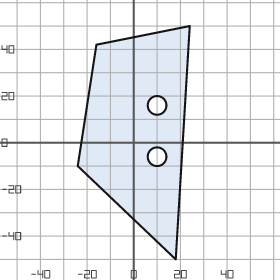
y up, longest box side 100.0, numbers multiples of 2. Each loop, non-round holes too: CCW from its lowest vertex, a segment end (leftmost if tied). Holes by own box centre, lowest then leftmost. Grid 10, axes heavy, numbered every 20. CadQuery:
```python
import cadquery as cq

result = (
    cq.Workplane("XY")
    .moveTo(18.0, -50.0)
    .lineTo(24.0, 50.0)
    .lineTo(-16.0, 42.0)
    .lineTo(-24.0, -10.0)
    .close()
    .moveTo(10.0, -6.0)
    .circle(4.0)
    .moveTo(10.0, 16.0)
    .circle(4.0)
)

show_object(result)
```